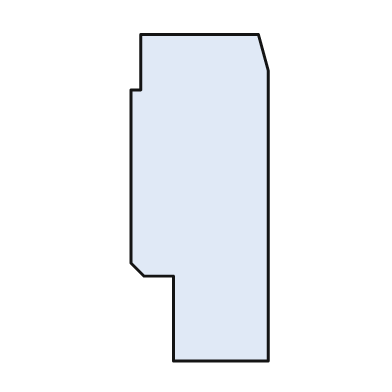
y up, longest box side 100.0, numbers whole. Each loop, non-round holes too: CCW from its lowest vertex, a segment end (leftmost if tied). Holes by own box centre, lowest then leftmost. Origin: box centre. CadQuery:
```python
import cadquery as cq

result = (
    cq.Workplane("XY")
    .moveTo(-8.0, -50.0)
    .lineTo(21.0, -50.0)
    .lineTo(21.0, 39.0)
    .lineTo(18.0, 50.0)
    .lineTo(-18.0, 50.0)
    .lineTo(-18.0, 33.0)
    .lineTo(-21.0, 33.0)
    .lineTo(-21.0, -20.0)
    .lineTo(-17.0, -24.0)
    .lineTo(-8.0, -24.0)
    .close()
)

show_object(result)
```